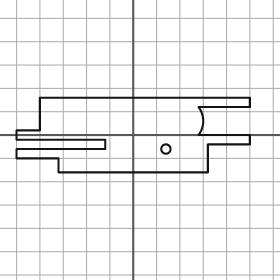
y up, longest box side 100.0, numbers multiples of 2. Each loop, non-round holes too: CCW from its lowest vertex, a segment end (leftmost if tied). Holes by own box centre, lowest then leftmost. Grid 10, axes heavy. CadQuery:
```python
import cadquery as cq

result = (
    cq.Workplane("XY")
    .moveTo(-32.0, -16.0)
    .lineTo(32.0, -16.0)
    .lineTo(32.0, -4.0)
    .lineTo(50.0, -4.0)
    .lineTo(50.0, 0.0)
    .lineTo(28.0, 0.0)
    .threePointArc((30.0, 6.0), (28.0, 12.0))
    .lineTo(50.0, 12.0)
    .lineTo(50.0, 16.0)
    .lineTo(-40.0, 16.0)
    .lineTo(-40.0, 2.0)
    .lineTo(-50.0, 2.0)
    .lineTo(-50.0, -2.0)
    .lineTo(-12.0, -2.0)
    .lineTo(-12.0, -6.0)
    .lineTo(-50.0, -6.0)
    .lineTo(-50.0, -10.0)
    .lineTo(-32.0, -10.0)
    .close()
    .moveTo(14.0, -6.0)
    .circle(2.0)
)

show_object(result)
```